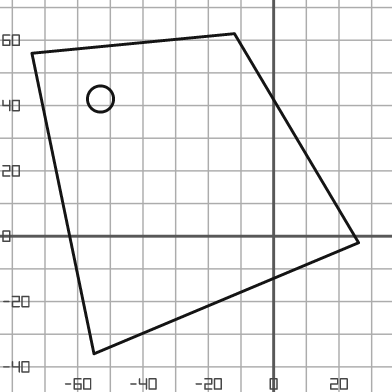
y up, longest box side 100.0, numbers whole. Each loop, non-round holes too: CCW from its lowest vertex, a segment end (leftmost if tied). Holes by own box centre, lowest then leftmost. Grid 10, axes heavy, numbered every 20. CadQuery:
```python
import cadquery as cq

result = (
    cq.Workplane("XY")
    .moveTo(-55.0, -36.0)
    .lineTo(26.0, -2.0)
    .lineTo(-12.0, 62.0)
    .lineTo(-74.0, 56.0)
    .close()
    .moveTo(-53.0, 42.0)
    .circle(4.0)
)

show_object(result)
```